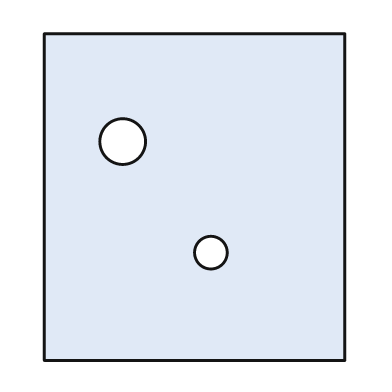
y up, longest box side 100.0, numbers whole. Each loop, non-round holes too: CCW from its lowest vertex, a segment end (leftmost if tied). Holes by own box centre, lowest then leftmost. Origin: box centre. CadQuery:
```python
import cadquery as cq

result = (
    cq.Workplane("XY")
    .moveTo(-46.0, -50.0)
    .lineTo(46.0, -50.0)
    .lineTo(46.0, 50.0)
    .lineTo(-46.0, 50.0)
    .close()
    .moveTo(5.0, -17.0)
    .circle(5.0)
    .moveTo(-22.0, 17.0)
    .circle(7.0)
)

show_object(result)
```